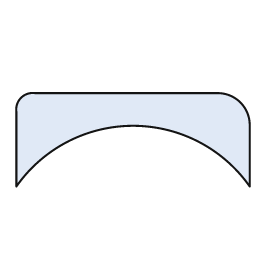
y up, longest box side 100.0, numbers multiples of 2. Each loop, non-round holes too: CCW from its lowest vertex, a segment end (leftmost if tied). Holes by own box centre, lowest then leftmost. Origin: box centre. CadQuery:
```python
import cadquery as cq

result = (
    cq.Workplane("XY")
    .moveTo(-50.0, -20.0)
    .threePointArc((0.0, 6.0), (50.0, -20.0))
    .lineTo(50.0, 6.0)
    .threePointArc((46.0, 16.0), (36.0, 20.0))
    .lineTo(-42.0, 20.0)
    .threePointArc((-48.0, 18.0), (-50.0, 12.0))
    .close()
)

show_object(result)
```